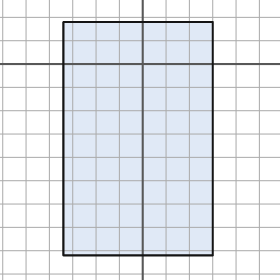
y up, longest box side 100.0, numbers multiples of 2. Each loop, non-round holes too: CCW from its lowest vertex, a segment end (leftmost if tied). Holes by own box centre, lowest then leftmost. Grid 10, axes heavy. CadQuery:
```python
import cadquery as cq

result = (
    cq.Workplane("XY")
    .moveTo(-34.0, -82.0)
    .lineTo(30.0, -82.0)
    .lineTo(30.0, 18.0)
    .lineTo(-34.0, 18.0)
    .close()
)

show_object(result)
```